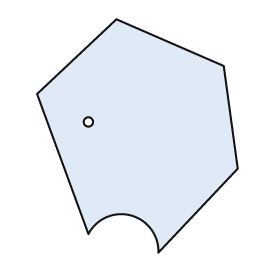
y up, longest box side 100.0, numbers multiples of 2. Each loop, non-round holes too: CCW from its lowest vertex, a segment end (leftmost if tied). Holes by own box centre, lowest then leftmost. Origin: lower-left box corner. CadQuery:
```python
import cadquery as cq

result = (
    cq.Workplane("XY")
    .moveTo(52.0, 0.0)
    .lineTo(86.0, 36.0)
    .lineTo(80.0, 80.0)
    .lineTo(34.0, 100.0)
    .lineTo(0.0, 68.0)
    .lineTo(22.0, 8.0)
    .threePointArc((40.0, 16.0), (52.0, 0.0))
    .close()
    .moveTo(22.0, 56.0)
    .circle(2.0)
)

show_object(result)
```